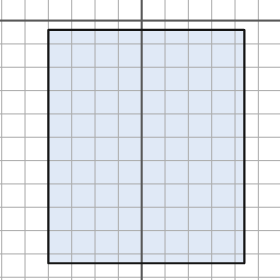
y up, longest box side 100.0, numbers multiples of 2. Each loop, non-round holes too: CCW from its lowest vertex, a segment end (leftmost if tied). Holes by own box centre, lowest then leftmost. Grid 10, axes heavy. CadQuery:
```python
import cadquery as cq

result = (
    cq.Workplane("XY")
    .moveTo(-40.0, -104.0)
    .lineTo(44.0, -104.0)
    .lineTo(44.0, -4.0)
    .lineTo(-40.0, -4.0)
    .close()
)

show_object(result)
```